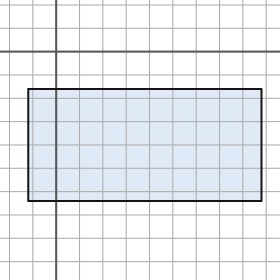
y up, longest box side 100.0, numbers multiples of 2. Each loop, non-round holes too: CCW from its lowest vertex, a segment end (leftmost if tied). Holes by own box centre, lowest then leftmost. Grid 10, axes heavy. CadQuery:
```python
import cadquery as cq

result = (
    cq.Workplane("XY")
    .moveTo(-12.0, -64.0)
    .lineTo(88.0, -64.0)
    .lineTo(88.0, -16.0)
    .lineTo(-12.0, -16.0)
    .close()
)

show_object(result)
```